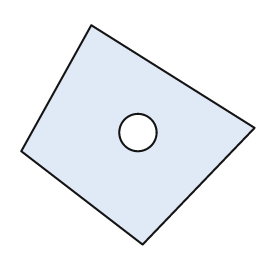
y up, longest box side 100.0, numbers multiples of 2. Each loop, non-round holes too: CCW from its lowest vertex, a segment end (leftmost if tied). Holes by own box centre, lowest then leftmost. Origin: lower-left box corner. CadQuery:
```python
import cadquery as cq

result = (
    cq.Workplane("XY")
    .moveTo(52.0, 0.0)
    .lineTo(100.0, 50.0)
    .lineTo(30.0, 94.0)
    .lineTo(0.0, 40.0)
    .close()
    .moveTo(50.0, 48.0)
    .circle(8.0)
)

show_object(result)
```